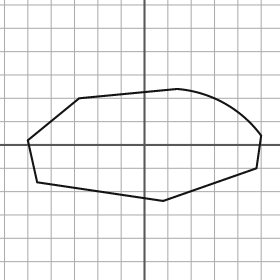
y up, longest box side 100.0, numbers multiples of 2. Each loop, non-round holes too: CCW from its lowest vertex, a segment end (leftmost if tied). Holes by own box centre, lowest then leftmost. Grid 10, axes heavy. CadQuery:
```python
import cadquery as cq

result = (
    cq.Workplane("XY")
    .moveTo(8.0, -24.0)
    .lineTo(48.0, -10.0)
    .lineTo(50.0, 4.0)
    .threePointArc((34.0, 18.0), (14.0, 24.0))
    .lineTo(-28.0, 20.0)
    .lineTo(-50.0, 2.0)
    .lineTo(-46.0, -16.0)
    .close()
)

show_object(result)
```